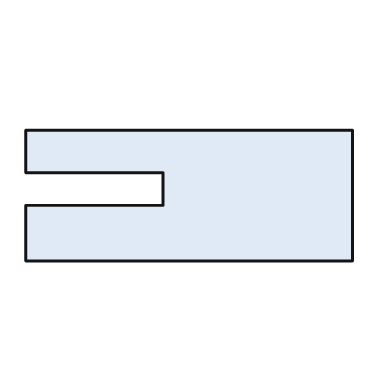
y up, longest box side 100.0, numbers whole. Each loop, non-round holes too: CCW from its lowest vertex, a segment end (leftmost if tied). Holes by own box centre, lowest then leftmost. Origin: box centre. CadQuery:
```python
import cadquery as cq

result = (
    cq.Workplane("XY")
    .moveTo(-50.0, -20.0)
    .lineTo(50.0, -20.0)
    .lineTo(50.0, 20.0)
    .lineTo(-50.0, 20.0)
    .lineTo(-50.0, 7.0)
    .lineTo(-8.0, 7.0)
    .lineTo(-8.0, -3.0)
    .lineTo(-50.0, -3.0)
    .close()
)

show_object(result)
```